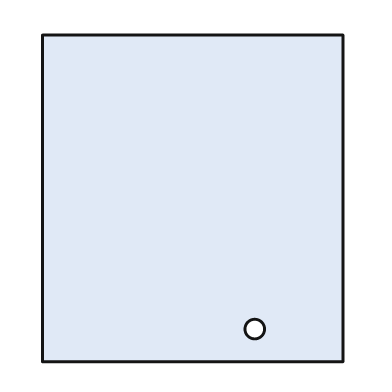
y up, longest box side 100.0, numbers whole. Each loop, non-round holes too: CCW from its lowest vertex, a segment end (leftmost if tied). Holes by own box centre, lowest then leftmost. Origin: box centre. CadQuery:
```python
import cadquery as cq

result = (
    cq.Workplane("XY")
    .moveTo(-46.0, -50.0)
    .lineTo(46.0, -50.0)
    .lineTo(46.0, 50.0)
    .lineTo(-46.0, 50.0)
    .close()
    .moveTo(19.0, -40.0)
    .circle(3.0)
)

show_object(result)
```